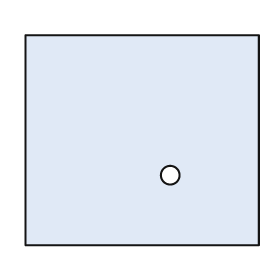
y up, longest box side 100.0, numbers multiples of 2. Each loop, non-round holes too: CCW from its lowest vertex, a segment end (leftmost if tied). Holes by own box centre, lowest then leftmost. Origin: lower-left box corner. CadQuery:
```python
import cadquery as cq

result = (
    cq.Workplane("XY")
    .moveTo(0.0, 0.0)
    .lineTo(100.0, 0.0)
    .lineTo(100.0, 90.0)
    .lineTo(0.0, 90.0)
    .close()
    .moveTo(62.0, 30.0)
    .circle(4.0)
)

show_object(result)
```